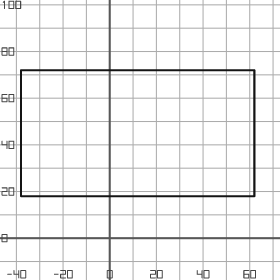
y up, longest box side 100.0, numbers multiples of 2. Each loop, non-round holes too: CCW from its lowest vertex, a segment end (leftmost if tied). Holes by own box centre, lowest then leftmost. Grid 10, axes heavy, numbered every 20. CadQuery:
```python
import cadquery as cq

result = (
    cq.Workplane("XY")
    .moveTo(-38.0, 18.0)
    .lineTo(62.0, 18.0)
    .lineTo(62.0, 72.0)
    .lineTo(-38.0, 72.0)
    .close()
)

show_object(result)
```